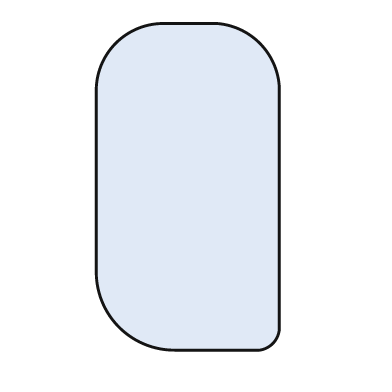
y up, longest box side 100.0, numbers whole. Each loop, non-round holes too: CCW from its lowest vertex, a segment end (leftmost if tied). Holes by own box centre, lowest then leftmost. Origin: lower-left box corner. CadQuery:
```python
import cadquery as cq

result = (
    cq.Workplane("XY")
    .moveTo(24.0, 0.0)
    .lineTo(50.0, 0.0)
    .threePointArc((54.0, 2.0), (56.0, 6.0))
    .lineTo(56.0, 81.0)
    .threePointArc((50.0, 94.0), (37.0, 100.0))
    .lineTo(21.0, 100.0)
    .threePointArc((6.0, 94.0), (0.0, 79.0))
    .lineTo(0.0, 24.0)
    .threePointArc((7.0, 7.0), (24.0, 0.0))
    .close()
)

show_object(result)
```